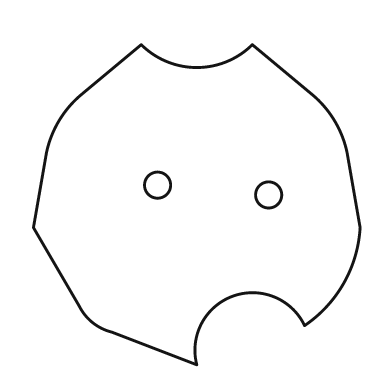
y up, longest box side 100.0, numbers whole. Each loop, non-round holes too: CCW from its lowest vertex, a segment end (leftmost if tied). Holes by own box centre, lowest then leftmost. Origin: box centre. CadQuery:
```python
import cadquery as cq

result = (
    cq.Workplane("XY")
    .moveTo(0.0, -49.0)
    .threePointArc((11.0, -28.0), (33.0, -37.0))
    .threePointArc((45.0, -24.0), (50.0, -7.0))
    .lineTo(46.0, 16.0)
    .threePointArc((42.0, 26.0), (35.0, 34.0))
    .lineTo(17.0, 49.0)
    .threePointArc((0.0, 42.0), (-17.0, 49.0))
    .lineTo(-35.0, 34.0)
    .threePointArc((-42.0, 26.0), (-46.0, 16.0))
    .lineTo(-50.0, -7.0)
    .lineTo(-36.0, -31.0)
    .threePointArc((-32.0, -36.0), (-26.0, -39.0))
    .close()
    .moveTo(22.0, 3.0)
    .circle(4.0)
    .moveTo(-12.0, 6.0)
    .circle(4.0)
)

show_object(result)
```